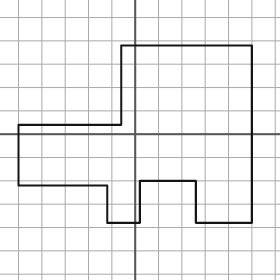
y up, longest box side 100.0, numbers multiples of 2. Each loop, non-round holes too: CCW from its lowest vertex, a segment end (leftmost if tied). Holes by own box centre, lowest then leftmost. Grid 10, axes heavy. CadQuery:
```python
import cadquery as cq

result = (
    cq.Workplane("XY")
    .moveTo(-12.0, -38.0)
    .lineTo(2.0, -38.0)
    .lineTo(2.0, -20.0)
    .lineTo(26.0, -20.0)
    .lineTo(26.0, -38.0)
    .lineTo(50.0, -38.0)
    .lineTo(50.0, 38.0)
    .lineTo(-6.0, 38.0)
    .lineTo(-6.0, 4.0)
    .lineTo(-50.0, 4.0)
    .lineTo(-50.0, -22.0)
    .lineTo(-12.0, -22.0)
    .close()
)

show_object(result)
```